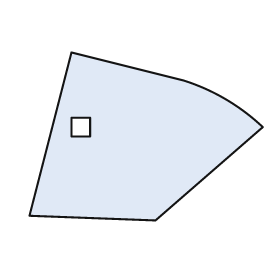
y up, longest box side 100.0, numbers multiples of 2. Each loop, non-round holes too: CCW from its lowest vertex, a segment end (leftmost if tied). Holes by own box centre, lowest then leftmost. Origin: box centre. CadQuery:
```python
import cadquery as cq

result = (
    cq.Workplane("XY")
    .moveTo(4.0, -36.0)
    .lineTo(50.0, 4.0)
    .threePointArc((34.0, 16.0), (16.0, 24.0))
    .lineTo(-32.0, 36.0)
    .lineTo(-50.0, -34.0)
    .close()
    .moveTo(-32.0, 0.0)
    .lineTo(-24.0, 0.0)
    .lineTo(-24.0, 8.0)
    .lineTo(-32.0, 8.0)
    .close()
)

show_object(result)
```